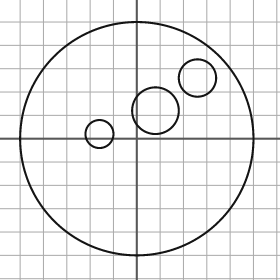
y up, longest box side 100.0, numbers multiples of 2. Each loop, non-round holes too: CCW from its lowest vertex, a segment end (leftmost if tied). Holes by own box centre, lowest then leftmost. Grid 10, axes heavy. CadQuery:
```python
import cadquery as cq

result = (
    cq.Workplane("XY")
    .moveTo(0.0, 0.0)
    .circle(50.0)
    .moveTo(-16.0, 2.0)
    .circle(6.0)
    .moveTo(8.0, 12.0)
    .circle(10.0)
    .moveTo(26.0, 26.0)
    .circle(8.0)
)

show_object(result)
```